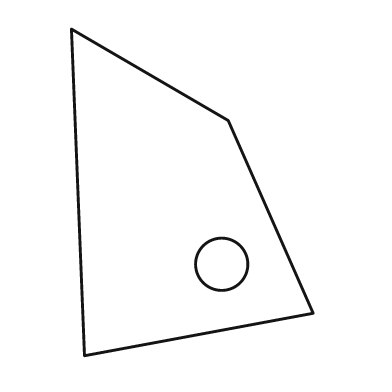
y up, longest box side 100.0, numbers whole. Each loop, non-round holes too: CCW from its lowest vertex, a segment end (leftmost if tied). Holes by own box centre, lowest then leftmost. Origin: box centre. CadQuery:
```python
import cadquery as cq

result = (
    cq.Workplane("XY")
    .moveTo(-33.0, -50.0)
    .lineTo(37.0, -37.0)
    .lineTo(11.0, 22.0)
    .lineTo(-37.0, 50.0)
    .close()
    .moveTo(9.0, -22.0)
    .circle(8.0)
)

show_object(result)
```